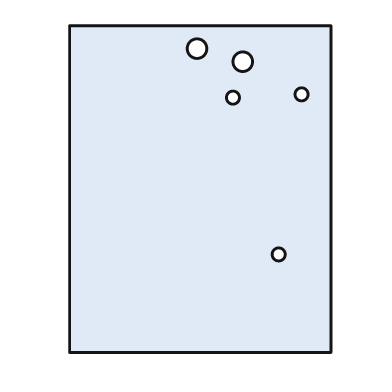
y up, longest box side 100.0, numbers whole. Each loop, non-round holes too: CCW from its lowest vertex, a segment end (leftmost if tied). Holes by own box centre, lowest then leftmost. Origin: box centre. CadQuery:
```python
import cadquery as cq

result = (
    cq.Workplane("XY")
    .moveTo(-40.0, -50.0)
    .lineTo(40.0, -50.0)
    .lineTo(40.0, 50.0)
    .lineTo(-40.0, 50.0)
    .close()
    .moveTo(24.0, -20.0)
    .circle(2.0)
    .moveTo(10.0, 28.0)
    .circle(2.0)
    .moveTo(31.0, 29.0)
    .circle(2.0)
    .moveTo(13.0, 39.0)
    .circle(3.0)
    .moveTo(-1.0, 43.0)
    .circle(3.0)
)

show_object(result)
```